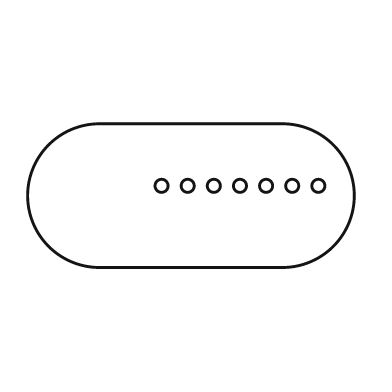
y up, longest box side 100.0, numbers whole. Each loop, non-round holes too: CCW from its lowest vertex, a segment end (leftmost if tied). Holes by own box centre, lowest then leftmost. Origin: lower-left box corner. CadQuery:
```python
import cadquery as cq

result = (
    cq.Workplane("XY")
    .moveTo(22.0, 0.0)
    .lineTo(78.0, 0.0)
    .threePointArc((100.0, 22.0), (78.0, 44.0))
    .lineTo(22.0, 44.0)
    .threePointArc((0.0, 22.0), (22.0, 0.0))
    .close()
    .moveTo(41.0, 25.0)
    .circle(2.0)
    .moveTo(49.0, 25.0)
    .circle(2.0)
    .moveTo(57.0, 25.0)
    .circle(2.0)
    .moveTo(65.0, 25.0)
    .circle(2.0)
    .moveTo(73.0, 25.0)
    .circle(2.0)
    .moveTo(81.0, 25.0)
    .circle(2.0)
    .moveTo(89.0, 25.0)
    .circle(2.0)
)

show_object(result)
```